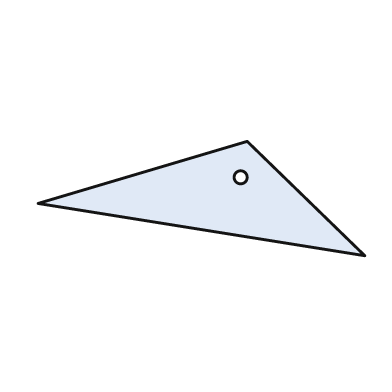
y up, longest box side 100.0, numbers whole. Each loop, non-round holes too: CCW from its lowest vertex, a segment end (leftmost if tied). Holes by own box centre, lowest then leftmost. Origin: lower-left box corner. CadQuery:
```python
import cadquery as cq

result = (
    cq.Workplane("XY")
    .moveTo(100.0, 0.0)
    .lineTo(64.0, 35.0)
    .lineTo(0.0, 16.0)
    .close()
    .moveTo(62.0, 24.0)
    .circle(2.0)
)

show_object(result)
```